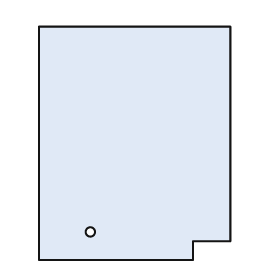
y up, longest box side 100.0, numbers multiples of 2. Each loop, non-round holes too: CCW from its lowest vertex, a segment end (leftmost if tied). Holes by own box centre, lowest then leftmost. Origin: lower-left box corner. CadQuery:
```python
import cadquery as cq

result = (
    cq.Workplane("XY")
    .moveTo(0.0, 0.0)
    .lineTo(66.0, 0.0)
    .lineTo(66.0, 8.0)
    .lineTo(82.0, 8.0)
    .lineTo(82.0, 100.0)
    .lineTo(0.0, 100.0)
    .close()
    .moveTo(22.0, 12.0)
    .circle(2.0)
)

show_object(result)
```